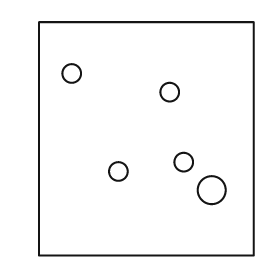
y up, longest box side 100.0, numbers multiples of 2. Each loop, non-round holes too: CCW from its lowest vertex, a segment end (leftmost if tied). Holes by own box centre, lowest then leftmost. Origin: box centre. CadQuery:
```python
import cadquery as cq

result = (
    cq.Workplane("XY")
    .moveTo(-46.0, -50.0)
    .lineTo(46.0, -50.0)
    .lineTo(46.0, 50.0)
    .lineTo(-46.0, 50.0)
    .close()
    .moveTo(28.0, -22.0)
    .circle(6.0)
    .moveTo(-12.0, -14.0)
    .circle(4.0)
    .moveTo(16.0, -10.0)
    .circle(4.0)
    .moveTo(10.0, 20.0)
    .circle(4.0)
    .moveTo(-32.0, 28.0)
    .circle(4.0)
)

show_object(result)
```